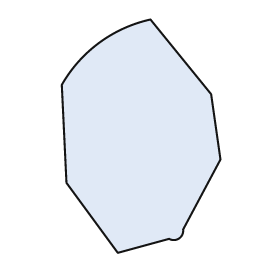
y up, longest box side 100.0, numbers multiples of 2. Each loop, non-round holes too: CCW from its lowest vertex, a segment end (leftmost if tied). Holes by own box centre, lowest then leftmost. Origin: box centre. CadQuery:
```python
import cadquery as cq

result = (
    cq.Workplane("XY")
    .moveTo(-10.0, -50.0)
    .lineTo(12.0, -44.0)
    .threePointArc((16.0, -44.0), (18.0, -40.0))
    .lineTo(34.0, -10.0)
    .lineTo(30.0, 18.0)
    .lineTo(4.0, 50.0)
    .threePointArc((-18.0, 40.0), (-34.0, 22.0))
    .lineTo(-32.0, -20.0)
    .close()
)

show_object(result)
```